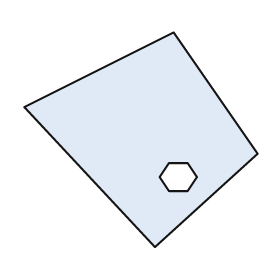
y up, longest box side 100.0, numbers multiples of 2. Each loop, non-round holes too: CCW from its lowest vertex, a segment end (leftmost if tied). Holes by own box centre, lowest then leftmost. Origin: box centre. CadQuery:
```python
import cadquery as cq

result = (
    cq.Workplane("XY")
    .moveTo(6.0, -46.0)
    .lineTo(50.0, -6.0)
    .lineTo(14.0, 46.0)
    .lineTo(-50.0, 14.0)
    .close()
    .moveTo(12.0, -22.0)
    .lineTo(20.0, -22.0)
    .lineTo(24.0, -16.0)
    .lineTo(20.0, -10.0)
    .lineTo(12.0, -10.0)
    .lineTo(8.0, -16.0)
    .close()
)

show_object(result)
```